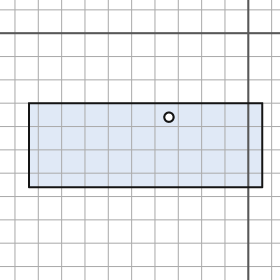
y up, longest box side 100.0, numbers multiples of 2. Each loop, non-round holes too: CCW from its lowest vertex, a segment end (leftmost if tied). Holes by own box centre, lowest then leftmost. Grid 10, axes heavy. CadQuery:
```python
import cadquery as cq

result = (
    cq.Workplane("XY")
    .moveTo(-94.0, -66.0)
    .lineTo(6.0, -66.0)
    .lineTo(6.0, -30.0)
    .lineTo(-94.0, -30.0)
    .close()
    .moveTo(-34.0, -36.0)
    .circle(2.0)
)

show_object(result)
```